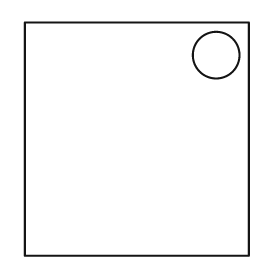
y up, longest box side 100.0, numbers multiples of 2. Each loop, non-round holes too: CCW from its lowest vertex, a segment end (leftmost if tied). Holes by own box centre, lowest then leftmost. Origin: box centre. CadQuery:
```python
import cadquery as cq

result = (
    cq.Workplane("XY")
    .moveTo(-48.0, -50.0)
    .lineTo(48.0, -50.0)
    .lineTo(48.0, 50.0)
    .lineTo(-48.0, 50.0)
    .close()
    .moveTo(34.0, 36.0)
    .circle(10.0)
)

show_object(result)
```